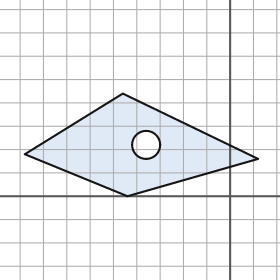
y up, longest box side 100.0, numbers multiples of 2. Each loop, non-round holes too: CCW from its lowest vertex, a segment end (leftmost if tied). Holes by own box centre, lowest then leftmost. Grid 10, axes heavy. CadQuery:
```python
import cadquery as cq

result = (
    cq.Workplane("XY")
    .moveTo(-44.0, 0.0)
    .lineTo(12.0, 16.0)
    .lineTo(-46.0, 44.0)
    .lineTo(-88.0, 18.0)
    .close()
    .moveTo(-36.0, 22.0)
    .circle(6.0)
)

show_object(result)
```